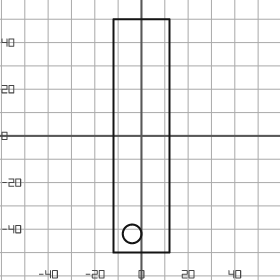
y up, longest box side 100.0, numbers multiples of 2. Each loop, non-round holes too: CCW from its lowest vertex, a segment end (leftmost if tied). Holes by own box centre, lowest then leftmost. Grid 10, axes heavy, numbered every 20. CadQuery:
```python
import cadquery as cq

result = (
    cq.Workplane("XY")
    .moveTo(-12.0, -50.0)
    .lineTo(12.0, -50.0)
    .lineTo(12.0, 50.0)
    .lineTo(-12.0, 50.0)
    .close()
    .moveTo(-4.0, -42.0)
    .circle(4.0)
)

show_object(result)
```